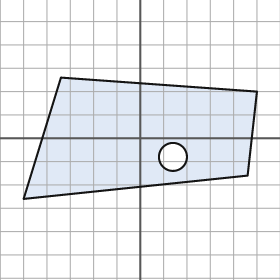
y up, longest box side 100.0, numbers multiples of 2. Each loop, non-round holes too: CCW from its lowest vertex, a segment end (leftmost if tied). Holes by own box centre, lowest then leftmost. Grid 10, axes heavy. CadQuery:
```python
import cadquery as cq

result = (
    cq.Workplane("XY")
    .moveTo(-50.0, -26.0)
    .lineTo(46.0, -16.0)
    .lineTo(50.0, 20.0)
    .lineTo(-34.0, 26.0)
    .close()
    .moveTo(14.0, -8.0)
    .circle(6.0)
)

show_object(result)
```